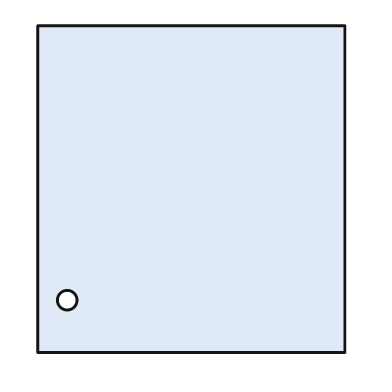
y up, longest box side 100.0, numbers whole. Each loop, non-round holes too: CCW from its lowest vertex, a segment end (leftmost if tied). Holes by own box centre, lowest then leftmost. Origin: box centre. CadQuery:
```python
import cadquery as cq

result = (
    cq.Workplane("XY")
    .moveTo(-47.0, -50.0)
    .lineTo(47.0, -50.0)
    .lineTo(47.0, 50.0)
    .lineTo(-47.0, 50.0)
    .close()
    .moveTo(-38.0, -34.0)
    .circle(3.0)
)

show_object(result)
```